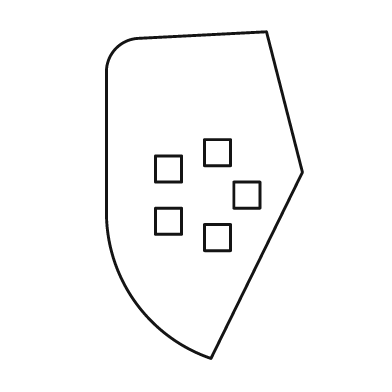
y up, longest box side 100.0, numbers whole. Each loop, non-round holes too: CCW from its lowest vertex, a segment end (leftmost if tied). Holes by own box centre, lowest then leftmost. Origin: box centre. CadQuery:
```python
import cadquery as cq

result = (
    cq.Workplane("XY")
    .moveTo(2.0, -50.0)
    .lineTo(30.0, 7.0)
    .lineTo(19.0, 50.0)
    .lineTo(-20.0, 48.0)
    .threePointArc((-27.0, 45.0), (-30.0, 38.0))
    .lineTo(-30.0, -6.0)
    .threePointArc((-21.0, -33.0), (2.0, -50.0))
    .close()
    .moveTo(0.0, -17.0)
    .lineTo(8.0, -17.0)
    .lineTo(8.0, -9.0)
    .lineTo(0.0, -9.0)
    .close()
    .moveTo(-15.0, -12.0)
    .lineTo(-7.0, -12.0)
    .lineTo(-7.0, -4.0)
    .lineTo(-15.0, -4.0)
    .close()
    .moveTo(9.0, -4.0)
    .lineTo(17.0, -4.0)
    .lineTo(17.0, 4.0)
    .lineTo(9.0, 4.0)
    .close()
    .moveTo(-15.0, 4.0)
    .lineTo(-7.0, 4.0)
    .lineTo(-7.0, 12.0)
    .lineTo(-15.0, 12.0)
    .close()
    .moveTo(0.0, 9.0)
    .lineTo(8.0, 9.0)
    .lineTo(8.0, 17.0)
    .lineTo(0.0, 17.0)
    .close()
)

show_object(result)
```